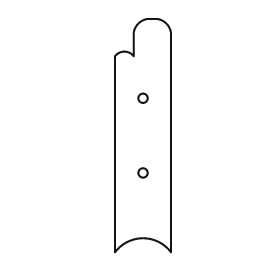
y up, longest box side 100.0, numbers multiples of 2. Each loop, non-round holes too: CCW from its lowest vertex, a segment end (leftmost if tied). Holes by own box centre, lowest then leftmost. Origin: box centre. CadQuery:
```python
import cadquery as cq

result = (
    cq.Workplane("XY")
    .moveTo(-12.0, -50.0)
    .threePointArc((0.0, -44.0), (12.0, -50.0))
    .lineTo(12.0, 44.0)
    .threePointArc((10.0, 48.0), (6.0, 50.0))
    .lineTo(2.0, 50.0)
    .threePointArc((-2.0, 48.0), (-4.0, 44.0))
    .lineTo(-4.0, 34.0)
    .threePointArc((-8.0, 36.0), (-12.0, 34.0))
    .close()
    .moveTo(0.0, -16.0)
    .circle(2.0)
    .moveTo(0.0, 16.0)
    .circle(2.0)
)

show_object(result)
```